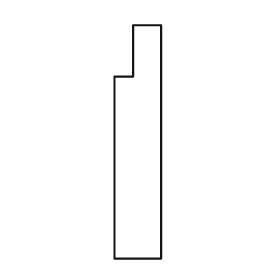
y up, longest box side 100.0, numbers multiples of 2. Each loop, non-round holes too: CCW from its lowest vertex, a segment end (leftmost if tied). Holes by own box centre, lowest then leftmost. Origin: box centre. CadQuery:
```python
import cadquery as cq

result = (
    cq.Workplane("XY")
    .moveTo(-10.0, -50.0)
    .lineTo(10.0, -50.0)
    .lineTo(10.0, 50.0)
    .lineTo(-2.0, 50.0)
    .lineTo(-2.0, 28.0)
    .lineTo(-10.0, 28.0)
    .close()
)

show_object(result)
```